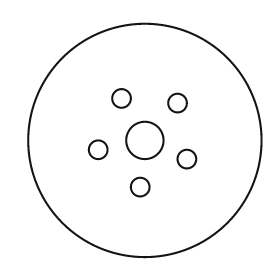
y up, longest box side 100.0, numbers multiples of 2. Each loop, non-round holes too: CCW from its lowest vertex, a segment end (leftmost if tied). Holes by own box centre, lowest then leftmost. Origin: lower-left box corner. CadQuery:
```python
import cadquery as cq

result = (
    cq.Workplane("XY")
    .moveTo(50.0, 50.0)
    .circle(50.0)
    .moveTo(48.0, 30.0)
    .circle(4.0)
    .moveTo(68.0, 42.0)
    .circle(4.0)
    .moveTo(30.0, 46.0)
    .circle(4.0)
    .moveTo(50.0, 50.0)
    .circle(8.0)
    .moveTo(64.0, 66.0)
    .circle(4.0)
    .moveTo(40.0, 68.0)
    .circle(4.0)
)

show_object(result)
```